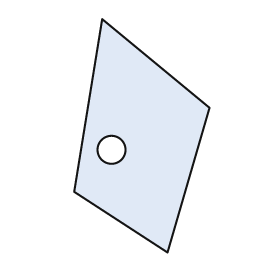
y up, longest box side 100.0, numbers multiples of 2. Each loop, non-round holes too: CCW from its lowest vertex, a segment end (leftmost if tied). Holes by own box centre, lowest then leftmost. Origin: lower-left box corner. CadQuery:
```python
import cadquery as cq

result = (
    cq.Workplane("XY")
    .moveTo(40.0, 0.0)
    .lineTo(58.0, 62.0)
    .lineTo(12.0, 100.0)
    .lineTo(0.0, 26.0)
    .close()
    .moveTo(16.0, 44.0)
    .circle(6.0)
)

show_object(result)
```